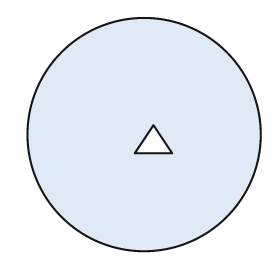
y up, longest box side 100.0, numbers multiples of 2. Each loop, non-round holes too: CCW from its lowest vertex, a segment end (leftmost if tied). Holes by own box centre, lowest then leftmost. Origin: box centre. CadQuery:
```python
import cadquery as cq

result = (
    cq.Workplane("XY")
    .moveTo(0.0, 0.0)
    .circle(50.0)
    .moveTo(-4.0, -8.0)
    .lineTo(12.0, -8.0)
    .lineTo(4.0, 4.0)
    .close()
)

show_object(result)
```